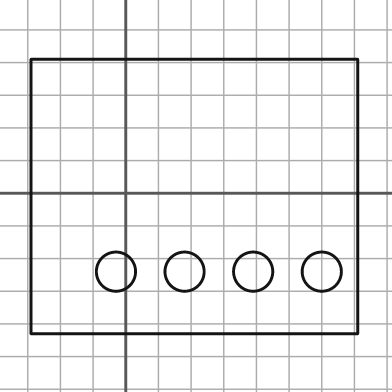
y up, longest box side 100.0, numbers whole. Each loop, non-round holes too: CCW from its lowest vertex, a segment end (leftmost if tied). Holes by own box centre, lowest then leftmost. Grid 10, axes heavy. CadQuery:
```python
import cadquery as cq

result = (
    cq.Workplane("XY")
    .moveTo(-29.0, -43.0)
    .lineTo(71.0, -43.0)
    .lineTo(71.0, 41.0)
    .lineTo(-29.0, 41.0)
    .close()
    .moveTo(-3.0, -24.0)
    .circle(6.0)
    .moveTo(18.0, -24.0)
    .circle(6.0)
    .moveTo(39.0, -24.0)
    .circle(6.0)
    .moveTo(60.0, -24.0)
    .circle(6.0)
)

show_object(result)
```